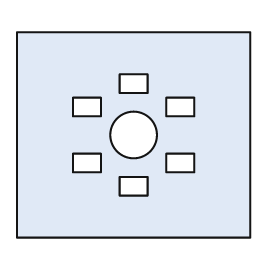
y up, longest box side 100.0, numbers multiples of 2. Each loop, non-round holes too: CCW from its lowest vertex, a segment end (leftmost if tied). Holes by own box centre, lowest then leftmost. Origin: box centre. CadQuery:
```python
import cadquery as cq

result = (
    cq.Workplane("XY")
    .moveTo(-50.0, -44.0)
    .lineTo(50.0, -44.0)
    .lineTo(50.0, 44.0)
    .lineTo(-50.0, 44.0)
    .close()
    .moveTo(-6.0, -26.0)
    .lineTo(6.0, -26.0)
    .lineTo(6.0, -18.0)
    .lineTo(-6.0, -18.0)
    .close()
    .moveTo(-26.0, -16.0)
    .lineTo(-14.0, -16.0)
    .lineTo(-14.0, -8.0)
    .lineTo(-26.0, -8.0)
    .close()
    .moveTo(14.0, -16.0)
    .lineTo(26.0, -16.0)
    .lineTo(26.0, -8.0)
    .lineTo(14.0, -8.0)
    .close()
    .moveTo(0.0, 0.0)
    .circle(10.0)
    .moveTo(-26.0, 8.0)
    .lineTo(-14.0, 8.0)
    .lineTo(-14.0, 16.0)
    .lineTo(-26.0, 16.0)
    .close()
    .moveTo(14.0, 8.0)
    .lineTo(26.0, 8.0)
    .lineTo(26.0, 16.0)
    .lineTo(14.0, 16.0)
    .close()
    .moveTo(-6.0, 18.0)
    .lineTo(6.0, 18.0)
    .lineTo(6.0, 26.0)
    .lineTo(-6.0, 26.0)
    .close()
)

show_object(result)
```